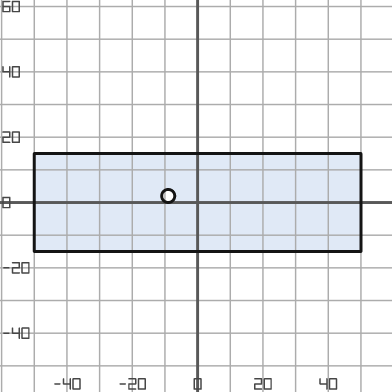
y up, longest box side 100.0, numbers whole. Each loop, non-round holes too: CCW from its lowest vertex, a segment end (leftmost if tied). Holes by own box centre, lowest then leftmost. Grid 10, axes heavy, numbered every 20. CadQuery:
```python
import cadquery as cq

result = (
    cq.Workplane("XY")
    .moveTo(-50.0, -15.0)
    .lineTo(50.0, -15.0)
    .lineTo(50.0, 15.0)
    .lineTo(-50.0, 15.0)
    .close()
    .moveTo(-9.0, 2.0)
    .circle(2.0)
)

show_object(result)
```